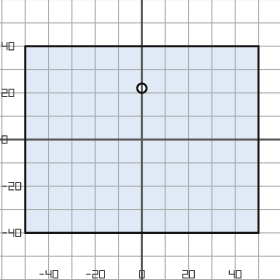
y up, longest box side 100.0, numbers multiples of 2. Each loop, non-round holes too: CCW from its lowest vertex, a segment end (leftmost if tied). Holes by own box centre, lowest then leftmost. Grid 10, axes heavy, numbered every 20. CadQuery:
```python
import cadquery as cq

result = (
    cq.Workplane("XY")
    .moveTo(-50.0, -40.0)
    .lineTo(50.0, -40.0)
    .lineTo(50.0, 40.0)
    .lineTo(-50.0, 40.0)
    .close()
    .moveTo(0.0, 22.0)
    .circle(2.0)
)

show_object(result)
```